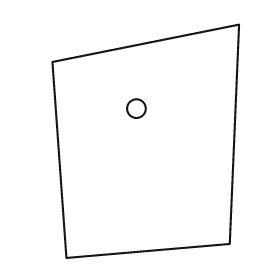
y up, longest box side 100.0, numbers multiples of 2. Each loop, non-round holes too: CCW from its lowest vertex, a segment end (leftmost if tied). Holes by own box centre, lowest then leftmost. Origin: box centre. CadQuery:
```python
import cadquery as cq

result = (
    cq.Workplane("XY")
    .moveTo(-34.0, -50.0)
    .lineTo(36.0, -44.0)
    .lineTo(40.0, 50.0)
    .lineTo(-40.0, 34.0)
    .close()
    .moveTo(-4.0, 14.0)
    .circle(4.0)
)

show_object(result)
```